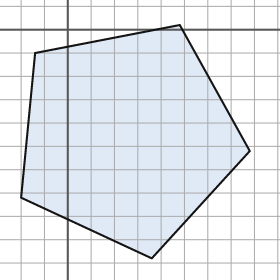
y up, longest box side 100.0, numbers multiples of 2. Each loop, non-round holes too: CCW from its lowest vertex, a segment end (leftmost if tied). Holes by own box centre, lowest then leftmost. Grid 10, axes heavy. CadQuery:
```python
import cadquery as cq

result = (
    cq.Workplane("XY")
    .moveTo(36.0, -98.0)
    .lineTo(78.0, -52.0)
    .lineTo(48.0, 2.0)
    .lineTo(-14.0, -10.0)
    .lineTo(-20.0, -72.0)
    .close()
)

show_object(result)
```